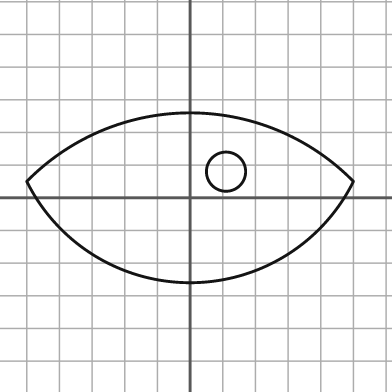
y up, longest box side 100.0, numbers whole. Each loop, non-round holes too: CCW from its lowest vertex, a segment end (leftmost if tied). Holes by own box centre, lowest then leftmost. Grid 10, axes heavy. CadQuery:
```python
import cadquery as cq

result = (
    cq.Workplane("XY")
    .moveTo(-50.0, 5.0)
    .threePointArc((0.0, -26.0), (50.0, 5.0))
    .threePointArc((0.0, 26.0), (-50.0, 5.0))
    .close()
    .moveTo(11.0, 8.0)
    .circle(6.0)
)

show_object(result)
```